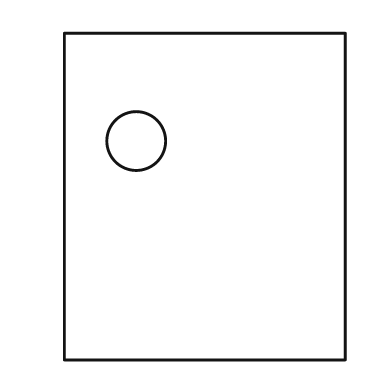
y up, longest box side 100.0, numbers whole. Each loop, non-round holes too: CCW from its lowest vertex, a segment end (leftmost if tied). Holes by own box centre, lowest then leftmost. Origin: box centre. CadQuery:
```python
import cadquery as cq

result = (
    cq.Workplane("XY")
    .moveTo(-43.0, -50.0)
    .lineTo(43.0, -50.0)
    .lineTo(43.0, 50.0)
    .lineTo(-43.0, 50.0)
    .close()
    .moveTo(-21.0, 17.0)
    .circle(9.0)
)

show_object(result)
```